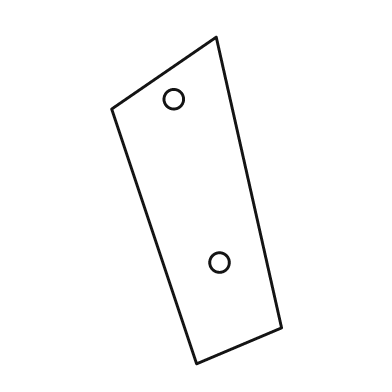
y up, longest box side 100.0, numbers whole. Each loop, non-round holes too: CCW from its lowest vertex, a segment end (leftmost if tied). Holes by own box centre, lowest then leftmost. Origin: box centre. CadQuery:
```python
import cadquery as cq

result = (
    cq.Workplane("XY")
    .moveTo(0.0, -50.0)
    .lineTo(26.0, -39.0)
    .lineTo(6.0, 50.0)
    .lineTo(-26.0, 28.0)
    .close()
    .moveTo(7.0, -19.0)
    .circle(3.0)
    .moveTo(-7.0, 31.0)
    .circle(3.0)
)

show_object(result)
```